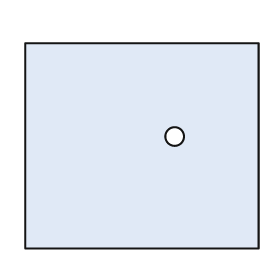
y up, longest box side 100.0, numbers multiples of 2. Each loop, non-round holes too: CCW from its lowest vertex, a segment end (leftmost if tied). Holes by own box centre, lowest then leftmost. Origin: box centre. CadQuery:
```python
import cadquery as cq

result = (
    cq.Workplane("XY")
    .moveTo(-50.0, -44.0)
    .lineTo(50.0, -44.0)
    .lineTo(50.0, 44.0)
    .lineTo(-50.0, 44.0)
    .close()
    .moveTo(14.0, 4.0)
    .circle(4.0)
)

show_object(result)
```